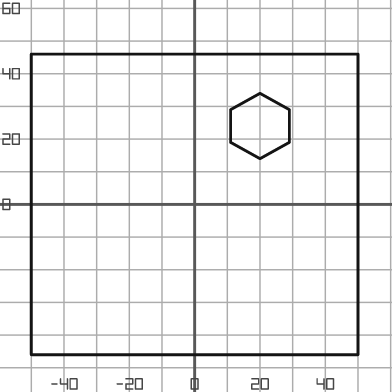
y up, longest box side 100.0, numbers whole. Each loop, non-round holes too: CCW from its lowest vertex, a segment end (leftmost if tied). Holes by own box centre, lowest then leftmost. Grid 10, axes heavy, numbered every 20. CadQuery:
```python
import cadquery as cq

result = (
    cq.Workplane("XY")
    .moveTo(-50.0, -46.0)
    .lineTo(50.0, -46.0)
    .lineTo(50.0, 46.0)
    .lineTo(-50.0, 46.0)
    .close()
    .moveTo(20.0, 14.0)
    .lineTo(29.0, 19.0)
    .lineTo(29.0, 29.0)
    .lineTo(20.0, 34.0)
    .lineTo(11.0, 29.0)
    .lineTo(11.0, 19.0)
    .close()
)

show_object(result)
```